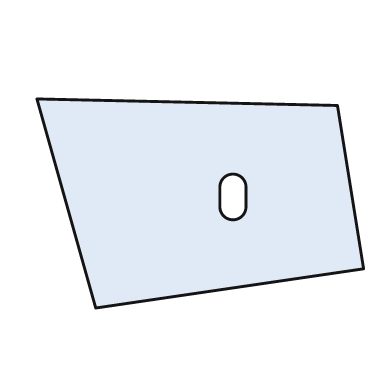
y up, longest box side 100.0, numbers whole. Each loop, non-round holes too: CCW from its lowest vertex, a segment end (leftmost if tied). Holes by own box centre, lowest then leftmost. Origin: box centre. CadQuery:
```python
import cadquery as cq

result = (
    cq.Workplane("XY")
    .moveTo(-32.0, -32.0)
    .lineTo(50.0, -20.0)
    .lineTo(42.0, 30.0)
    .lineTo(-50.0, 32.0)
    .close()
    .moveTo(6.0, -1.0)
    .threePointArc((10.0, -5.0), (14.0, -1.0))
    .lineTo(14.0, 5.0)
    .threePointArc((10.0, 9.0), (6.0, 5.0))
    .close()
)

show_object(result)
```